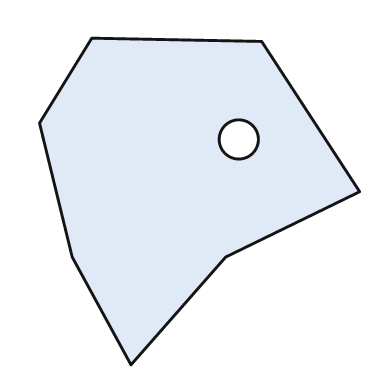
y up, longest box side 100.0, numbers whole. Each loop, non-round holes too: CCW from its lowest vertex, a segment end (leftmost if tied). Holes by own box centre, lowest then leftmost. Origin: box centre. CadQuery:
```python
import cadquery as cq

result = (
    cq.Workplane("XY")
    .moveTo(-21.0, -50.0)
    .lineTo(8.0, -17.0)
    .lineTo(49.0, 3.0)
    .lineTo(19.0, 49.0)
    .lineTo(-33.0, 50.0)
    .lineTo(-49.0, 24.0)
    .lineTo(-39.0, -17.0)
    .close()
    .moveTo(12.0, 19.0)
    .circle(6.0)
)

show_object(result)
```